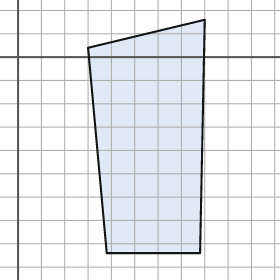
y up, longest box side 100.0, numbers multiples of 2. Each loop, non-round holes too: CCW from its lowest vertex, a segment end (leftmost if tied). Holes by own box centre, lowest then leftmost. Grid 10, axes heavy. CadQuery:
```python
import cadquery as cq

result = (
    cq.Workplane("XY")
    .moveTo(38.0, -84.0)
    .lineTo(78.0, -84.0)
    .lineTo(80.0, 16.0)
    .lineTo(30.0, 4.0)
    .close()
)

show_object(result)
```